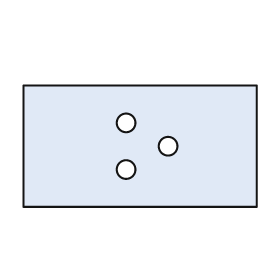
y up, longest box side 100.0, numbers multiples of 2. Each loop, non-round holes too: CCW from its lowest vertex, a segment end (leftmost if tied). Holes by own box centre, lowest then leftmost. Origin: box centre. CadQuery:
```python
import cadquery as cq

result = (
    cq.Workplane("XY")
    .moveTo(-50.0, -26.0)
    .lineTo(50.0, -26.0)
    .lineTo(50.0, 26.0)
    .lineTo(-50.0, 26.0)
    .close()
    .moveTo(-6.0, -10.0)
    .circle(4.0)
    .moveTo(12.0, 0.0)
    .circle(4.0)
    .moveTo(-6.0, 10.0)
    .circle(4.0)
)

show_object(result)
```